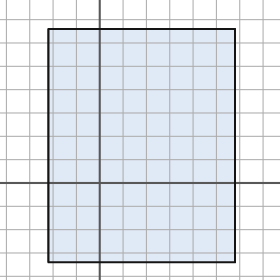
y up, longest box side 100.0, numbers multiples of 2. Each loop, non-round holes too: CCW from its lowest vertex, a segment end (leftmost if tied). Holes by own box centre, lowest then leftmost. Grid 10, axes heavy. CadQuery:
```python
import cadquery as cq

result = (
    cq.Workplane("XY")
    .moveTo(-22.0, -34.0)
    .lineTo(58.0, -34.0)
    .lineTo(58.0, 66.0)
    .lineTo(-22.0, 66.0)
    .close()
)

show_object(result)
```